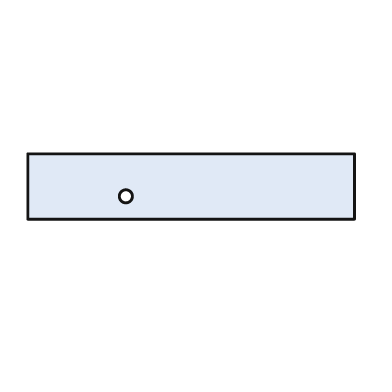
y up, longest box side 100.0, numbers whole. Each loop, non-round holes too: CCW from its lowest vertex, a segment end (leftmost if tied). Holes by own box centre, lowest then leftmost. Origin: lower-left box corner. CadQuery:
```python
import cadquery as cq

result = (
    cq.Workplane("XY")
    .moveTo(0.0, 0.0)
    .lineTo(100.0, 0.0)
    .lineTo(100.0, 20.0)
    .lineTo(0.0, 20.0)
    .close()
    .moveTo(30.0, 7.0)
    .circle(2.0)
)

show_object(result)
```